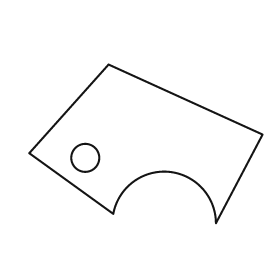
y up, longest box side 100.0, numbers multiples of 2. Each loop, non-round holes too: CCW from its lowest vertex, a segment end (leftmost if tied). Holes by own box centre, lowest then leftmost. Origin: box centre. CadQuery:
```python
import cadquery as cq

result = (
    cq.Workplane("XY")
    .moveTo(30.0, -34.0)
    .lineTo(50.0, 4.0)
    .lineTo(-16.0, 34.0)
    .lineTo(-50.0, -4.0)
    .lineTo(-14.0, -30.0)
    .threePointArc((10.0, -12.0), (30.0, -34.0))
    .close()
    .moveTo(-26.0, -6.0)
    .circle(6.0)
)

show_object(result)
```